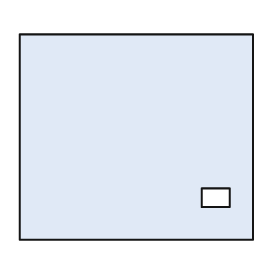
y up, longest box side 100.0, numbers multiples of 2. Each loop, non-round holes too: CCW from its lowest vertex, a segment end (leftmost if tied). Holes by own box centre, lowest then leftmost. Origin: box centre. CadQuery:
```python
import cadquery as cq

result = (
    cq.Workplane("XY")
    .moveTo(-50.0, -44.0)
    .lineTo(50.0, -44.0)
    .lineTo(50.0, 44.0)
    .lineTo(-50.0, 44.0)
    .close()
    .moveTo(28.0, -30.0)
    .lineTo(40.0, -30.0)
    .lineTo(40.0, -22.0)
    .lineTo(28.0, -22.0)
    .close()
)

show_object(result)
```